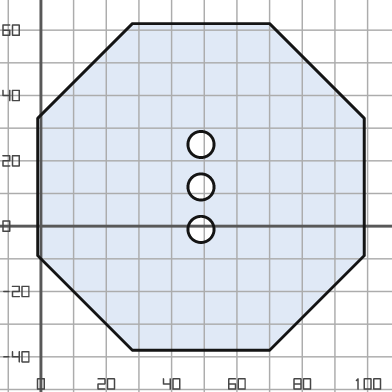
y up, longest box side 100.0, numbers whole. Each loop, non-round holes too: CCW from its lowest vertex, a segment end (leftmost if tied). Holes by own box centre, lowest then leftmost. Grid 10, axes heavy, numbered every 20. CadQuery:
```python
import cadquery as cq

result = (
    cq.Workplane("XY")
    .moveTo(28.0, -38.0)
    .lineTo(70.0, -38.0)
    .lineTo(99.0, -9.0)
    .lineTo(99.0, 33.0)
    .lineTo(70.0, 62.0)
    .lineTo(28.0, 62.0)
    .lineTo(-1.0, 33.0)
    .lineTo(-1.0, -9.0)
    .close()
    .moveTo(49.0, -1.0)
    .circle(4.0)
    .moveTo(49.0, 12.0)
    .circle(4.0)
    .moveTo(49.0, 25.0)
    .circle(4.0)
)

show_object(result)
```